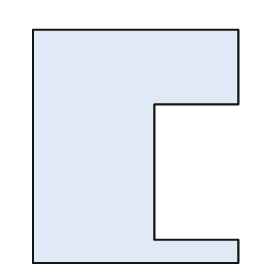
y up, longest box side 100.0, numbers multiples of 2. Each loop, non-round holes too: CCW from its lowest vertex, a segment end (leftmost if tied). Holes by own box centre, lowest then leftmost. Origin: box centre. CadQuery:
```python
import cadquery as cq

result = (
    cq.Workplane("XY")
    .moveTo(-44.0, -50.0)
    .lineTo(44.0, -50.0)
    .lineTo(44.0, -40.0)
    .lineTo(8.0, -40.0)
    .lineTo(8.0, 18.0)
    .lineTo(44.0, 18.0)
    .lineTo(44.0, 50.0)
    .lineTo(-44.0, 50.0)
    .close()
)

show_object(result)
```